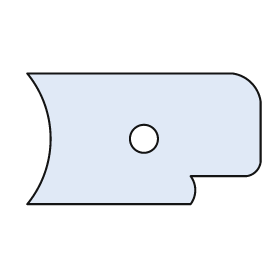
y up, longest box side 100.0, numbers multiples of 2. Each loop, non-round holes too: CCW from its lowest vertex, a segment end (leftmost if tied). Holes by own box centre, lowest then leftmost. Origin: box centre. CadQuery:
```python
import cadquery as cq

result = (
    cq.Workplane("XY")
    .moveTo(-50.0, -28.0)
    .lineTo(20.0, -28.0)
    .threePointArc((22.0, -22.0), (20.0, -16.0))
    .lineTo(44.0, -16.0)
    .threePointArc((48.0, -14.0), (50.0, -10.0))
    .lineTo(50.0, 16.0)
    .threePointArc((46.0, 24.0), (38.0, 28.0))
    .lineTo(-50.0, 28.0)
    .threePointArc((-40.0, 0.0), (-50.0, -28.0))
    .close()
    .moveTo(0.0, 0.0)
    .circle(6.0)
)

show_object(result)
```